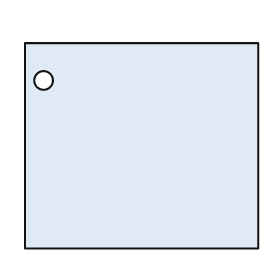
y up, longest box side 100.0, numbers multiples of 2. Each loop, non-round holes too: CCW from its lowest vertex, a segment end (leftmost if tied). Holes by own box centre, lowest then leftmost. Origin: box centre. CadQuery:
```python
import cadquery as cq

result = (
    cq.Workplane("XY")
    .moveTo(-50.0, -44.0)
    .lineTo(50.0, -44.0)
    .lineTo(50.0, 44.0)
    .lineTo(-50.0, 44.0)
    .close()
    .moveTo(-42.0, 28.0)
    .circle(4.0)
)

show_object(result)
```